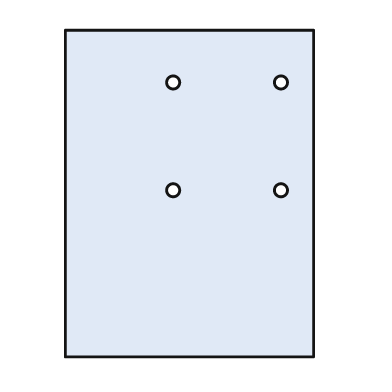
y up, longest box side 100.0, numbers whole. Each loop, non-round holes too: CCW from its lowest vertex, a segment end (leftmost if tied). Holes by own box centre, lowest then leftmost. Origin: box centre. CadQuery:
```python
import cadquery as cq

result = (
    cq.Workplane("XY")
    .moveTo(-38.0, -50.0)
    .lineTo(38.0, -50.0)
    .lineTo(38.0, 50.0)
    .lineTo(-38.0, 50.0)
    .close()
    .moveTo(-5.0, 1.0)
    .circle(2.0)
    .moveTo(28.0, 1.0)
    .circle(2.0)
    .moveTo(-5.0, 34.0)
    .circle(2.0)
    .moveTo(28.0, 34.0)
    .circle(2.0)
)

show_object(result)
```